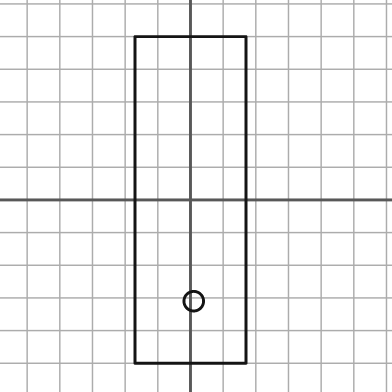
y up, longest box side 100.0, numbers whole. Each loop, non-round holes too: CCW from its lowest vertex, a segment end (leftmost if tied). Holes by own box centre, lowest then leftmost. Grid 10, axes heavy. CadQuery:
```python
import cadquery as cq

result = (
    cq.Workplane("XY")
    .moveTo(-17.0, -50.0)
    .lineTo(17.0, -50.0)
    .lineTo(17.0, 50.0)
    .lineTo(-17.0, 50.0)
    .close()
    .moveTo(1.0, -31.0)
    .circle(3.0)
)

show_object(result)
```